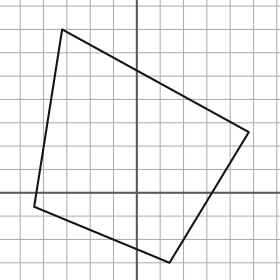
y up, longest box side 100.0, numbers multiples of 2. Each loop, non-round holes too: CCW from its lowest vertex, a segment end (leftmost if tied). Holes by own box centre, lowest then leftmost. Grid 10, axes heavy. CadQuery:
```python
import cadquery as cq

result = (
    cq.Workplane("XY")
    .moveTo(14.0, -30.0)
    .lineTo(48.0, 26.0)
    .lineTo(-32.0, 70.0)
    .lineTo(-44.0, -6.0)
    .close()
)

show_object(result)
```